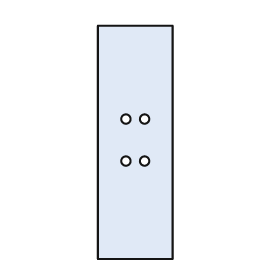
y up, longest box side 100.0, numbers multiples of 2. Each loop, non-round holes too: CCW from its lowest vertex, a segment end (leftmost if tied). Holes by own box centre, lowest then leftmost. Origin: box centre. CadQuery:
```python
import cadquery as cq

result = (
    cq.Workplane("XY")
    .moveTo(-16.0, -50.0)
    .lineTo(16.0, -50.0)
    .lineTo(16.0, 50.0)
    .lineTo(-16.0, 50.0)
    .close()
    .moveTo(-4.0, -8.0)
    .circle(2.0)
    .moveTo(4.0, -8.0)
    .circle(2.0)
    .moveTo(-4.0, 10.0)
    .circle(2.0)
    .moveTo(4.0, 10.0)
    .circle(2.0)
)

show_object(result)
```